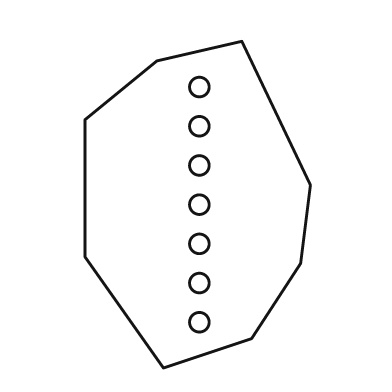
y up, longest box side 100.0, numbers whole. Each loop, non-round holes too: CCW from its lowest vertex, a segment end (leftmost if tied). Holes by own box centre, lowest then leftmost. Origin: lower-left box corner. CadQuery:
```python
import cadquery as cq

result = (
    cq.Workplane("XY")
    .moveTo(24.0, 0.0)
    .lineTo(51.0, 9.0)
    .lineTo(66.0, 32.0)
    .lineTo(69.0, 56.0)
    .lineTo(48.0, 100.0)
    .lineTo(22.0, 94.0)
    .lineTo(0.0, 76.0)
    .lineTo(0.0, 34.0)
    .close()
    .moveTo(35.0, 14.0)
    .circle(3.0)
    .moveTo(35.0, 26.0)
    .circle(3.0)
    .moveTo(35.0, 38.0)
    .circle(3.0)
    .moveTo(35.0, 50.0)
    .circle(3.0)
    .moveTo(35.0, 62.0)
    .circle(3.0)
    .moveTo(35.0, 74.0)
    .circle(3.0)
    .moveTo(35.0, 86.0)
    .circle(3.0)
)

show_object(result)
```